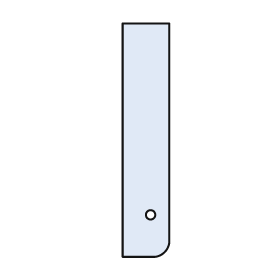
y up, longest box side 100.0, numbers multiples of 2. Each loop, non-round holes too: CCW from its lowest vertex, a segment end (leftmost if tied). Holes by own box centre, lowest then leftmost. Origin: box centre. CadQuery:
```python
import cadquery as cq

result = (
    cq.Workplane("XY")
    .moveTo(-10.0, -50.0)
    .lineTo(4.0, -50.0)
    .threePointArc((8.0, -48.0), (10.0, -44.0))
    .lineTo(10.0, 50.0)
    .lineTo(-10.0, 50.0)
    .close()
    .moveTo(2.0, -32.0)
    .circle(2.0)
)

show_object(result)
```